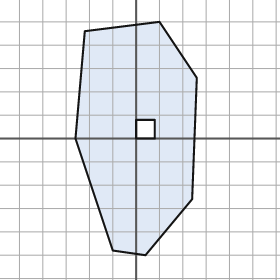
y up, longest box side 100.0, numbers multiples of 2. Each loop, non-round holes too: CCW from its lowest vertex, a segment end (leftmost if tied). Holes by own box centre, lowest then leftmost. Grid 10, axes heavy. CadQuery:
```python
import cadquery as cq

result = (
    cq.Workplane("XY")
    .moveTo(4.0, -50.0)
    .lineTo(24.0, -26.0)
    .lineTo(26.0, 26.0)
    .lineTo(10.0, 50.0)
    .lineTo(-22.0, 46.0)
    .lineTo(-26.0, 0.0)
    .lineTo(-10.0, -48.0)
    .close()
    .moveTo(0.0, 0.0)
    .lineTo(8.0, 0.0)
    .lineTo(8.0, 8.0)
    .lineTo(0.0, 8.0)
    .close()
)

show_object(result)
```